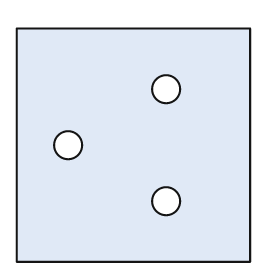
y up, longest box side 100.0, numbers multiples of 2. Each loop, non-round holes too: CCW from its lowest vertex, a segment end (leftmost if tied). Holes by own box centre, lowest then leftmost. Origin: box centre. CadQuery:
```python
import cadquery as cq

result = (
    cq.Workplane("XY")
    .moveTo(-50.0, -50.0)
    .lineTo(50.0, -50.0)
    .lineTo(50.0, 50.0)
    .lineTo(-50.0, 50.0)
    .close()
    .moveTo(14.0, -24.0)
    .circle(6.0)
    .moveTo(-28.0, 0.0)
    .circle(6.0)
    .moveTo(14.0, 24.0)
    .circle(6.0)
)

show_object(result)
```